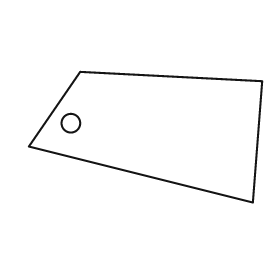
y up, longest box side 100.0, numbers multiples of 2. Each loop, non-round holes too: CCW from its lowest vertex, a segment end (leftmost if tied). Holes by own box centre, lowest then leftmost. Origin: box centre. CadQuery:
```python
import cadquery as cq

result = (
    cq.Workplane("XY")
    .moveTo(46.0, -28.0)
    .lineTo(50.0, 24.0)
    .lineTo(-28.0, 28.0)
    .lineTo(-50.0, -4.0)
    .close()
    .moveTo(-32.0, 6.0)
    .circle(4.0)
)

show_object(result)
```